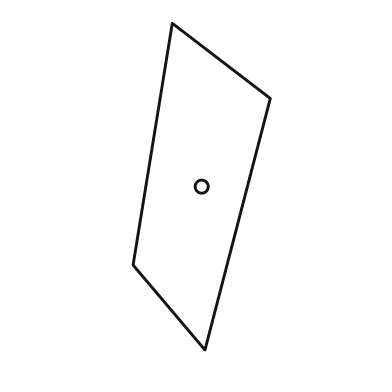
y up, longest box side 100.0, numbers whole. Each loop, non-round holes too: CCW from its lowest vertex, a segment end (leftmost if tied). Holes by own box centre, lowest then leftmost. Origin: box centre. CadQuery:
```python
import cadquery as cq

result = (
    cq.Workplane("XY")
    .moveTo(1.0, -50.0)
    .lineTo(21.0, 27.0)
    .lineTo(-9.0, 50.0)
    .lineTo(-21.0, -24.0)
    .close()
    .moveTo(0.0, 0.0)
    .circle(2.0)
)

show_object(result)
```